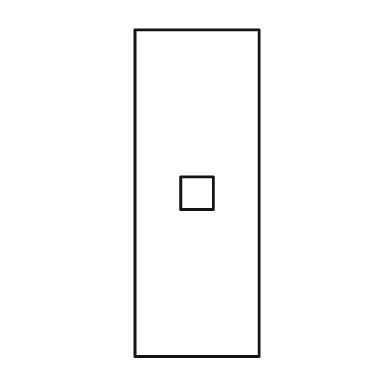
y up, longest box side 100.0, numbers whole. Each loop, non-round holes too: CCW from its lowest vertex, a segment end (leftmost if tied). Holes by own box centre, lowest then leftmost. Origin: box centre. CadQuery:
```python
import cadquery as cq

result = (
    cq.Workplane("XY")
    .moveTo(-19.0, -50.0)
    .lineTo(19.0, -50.0)
    .lineTo(19.0, 50.0)
    .lineTo(-19.0, 50.0)
    .close()
    .moveTo(-5.0, -5.0)
    .lineTo(5.0, -5.0)
    .lineTo(5.0, 5.0)
    .lineTo(-5.0, 5.0)
    .close()
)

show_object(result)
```